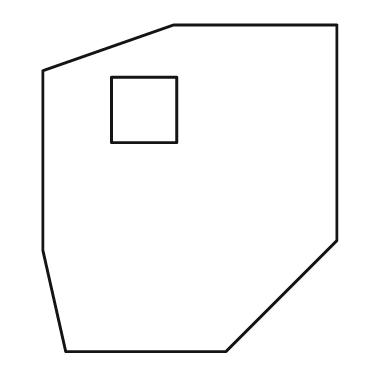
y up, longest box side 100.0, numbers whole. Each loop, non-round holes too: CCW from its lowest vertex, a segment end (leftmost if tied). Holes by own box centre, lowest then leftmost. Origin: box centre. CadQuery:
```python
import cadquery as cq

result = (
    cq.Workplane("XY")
    .moveTo(-38.0, -50.0)
    .lineTo(11.0, -50.0)
    .lineTo(45.0, -16.0)
    .lineTo(45.0, 50.0)
    .lineTo(-5.0, 50.0)
    .lineTo(-45.0, 36.0)
    .lineTo(-45.0, -19.0)
    .close()
    .moveTo(-24.0, 14.0)
    .lineTo(-4.0, 14.0)
    .lineTo(-4.0, 34.0)
    .lineTo(-24.0, 34.0)
    .close()
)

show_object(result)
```